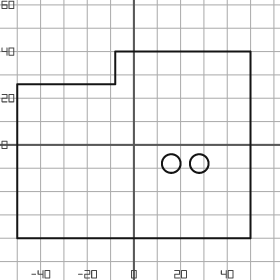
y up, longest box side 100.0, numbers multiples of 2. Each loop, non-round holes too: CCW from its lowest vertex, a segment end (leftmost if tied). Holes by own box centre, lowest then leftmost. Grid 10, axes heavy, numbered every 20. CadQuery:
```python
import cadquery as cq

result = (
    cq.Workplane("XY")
    .moveTo(-50.0, -40.0)
    .lineTo(50.0, -40.0)
    .lineTo(50.0, 40.0)
    .lineTo(-8.0, 40.0)
    .lineTo(-8.0, 26.0)
    .lineTo(-50.0, 26.0)
    .close()
    .moveTo(16.0, -8.0)
    .circle(4.0)
    .moveTo(28.0, -8.0)
    .circle(4.0)
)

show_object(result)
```